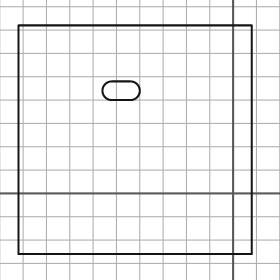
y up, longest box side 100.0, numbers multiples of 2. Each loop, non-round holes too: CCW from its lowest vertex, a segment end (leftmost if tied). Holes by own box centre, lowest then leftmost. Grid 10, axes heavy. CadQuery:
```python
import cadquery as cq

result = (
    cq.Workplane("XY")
    .moveTo(-92.0, -26.0)
    .lineTo(8.0, -26.0)
    .lineTo(8.0, 72.0)
    .lineTo(-92.0, 72.0)
    .close()
    .moveTo(-52.0, 40.0)
    .lineTo(-44.0, 40.0)
    .threePointArc((-40.0, 44.0), (-44.0, 48.0))
    .lineTo(-52.0, 48.0)
    .threePointArc((-56.0, 44.0), (-52.0, 40.0))
    .close()
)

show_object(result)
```